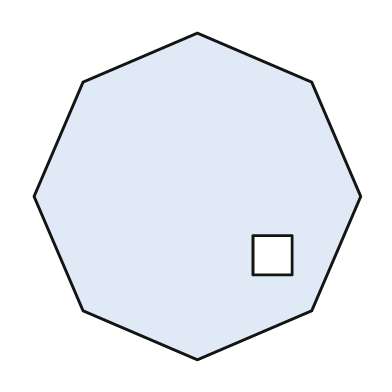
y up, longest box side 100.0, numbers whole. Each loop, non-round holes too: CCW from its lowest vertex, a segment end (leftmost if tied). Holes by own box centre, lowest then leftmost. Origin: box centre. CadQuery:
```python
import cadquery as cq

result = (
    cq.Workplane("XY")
    .moveTo(0.0, -50.0)
    .lineTo(35.0, -35.0)
    .lineTo(50.0, 0.0)
    .lineTo(35.0, 35.0)
    .lineTo(0.0, 50.0)
    .lineTo(-35.0, 35.0)
    .lineTo(-50.0, 0.0)
    .lineTo(-35.0, -35.0)
    .close()
    .moveTo(17.0, -24.0)
    .lineTo(29.0, -24.0)
    .lineTo(29.0, -12.0)
    .lineTo(17.0, -12.0)
    .close()
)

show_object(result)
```